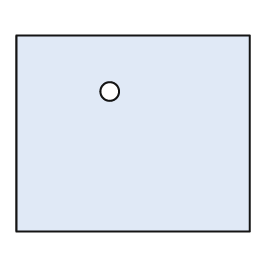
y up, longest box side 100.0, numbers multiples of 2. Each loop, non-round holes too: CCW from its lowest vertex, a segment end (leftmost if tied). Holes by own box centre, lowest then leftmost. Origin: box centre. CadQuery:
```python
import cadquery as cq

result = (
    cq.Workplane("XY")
    .moveTo(-50.0, -42.0)
    .lineTo(50.0, -42.0)
    .lineTo(50.0, 42.0)
    .lineTo(-50.0, 42.0)
    .close()
    .moveTo(-10.0, 18.0)
    .circle(4.0)
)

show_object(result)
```